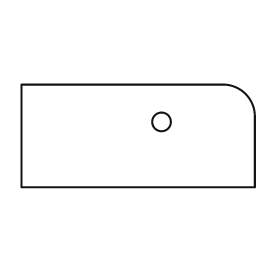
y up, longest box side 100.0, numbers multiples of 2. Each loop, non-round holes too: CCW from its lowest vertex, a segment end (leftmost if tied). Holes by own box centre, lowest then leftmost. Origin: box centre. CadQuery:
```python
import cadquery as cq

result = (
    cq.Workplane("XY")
    .moveTo(-50.0, -22.0)
    .lineTo(50.0, -22.0)
    .lineTo(50.0, 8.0)
    .threePointArc((46.0, 18.0), (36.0, 22.0))
    .lineTo(-50.0, 22.0)
    .close()
    .moveTo(10.0, 6.0)
    .circle(4.0)
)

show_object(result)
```